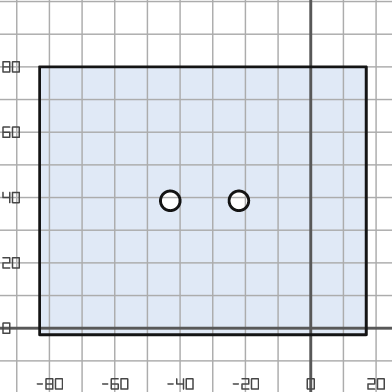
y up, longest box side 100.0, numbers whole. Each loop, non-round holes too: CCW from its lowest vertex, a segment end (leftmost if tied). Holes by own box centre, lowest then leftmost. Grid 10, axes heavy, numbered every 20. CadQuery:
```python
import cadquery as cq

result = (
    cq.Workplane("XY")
    .moveTo(-83.0, -2.0)
    .lineTo(17.0, -2.0)
    .lineTo(17.0, 80.0)
    .lineTo(-83.0, 80.0)
    .close()
    .moveTo(-43.0, 39.0)
    .circle(3.0)
    .moveTo(-22.0, 39.0)
    .circle(3.0)
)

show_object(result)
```